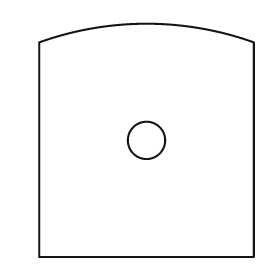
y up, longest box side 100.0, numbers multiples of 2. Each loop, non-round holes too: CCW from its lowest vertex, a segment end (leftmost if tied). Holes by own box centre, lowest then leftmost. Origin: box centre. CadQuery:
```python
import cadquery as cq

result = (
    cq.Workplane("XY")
    .moveTo(-46.0, -50.0)
    .lineTo(46.0, -50.0)
    .lineTo(46.0, 42.0)
    .threePointArc((0.0, 50.0), (-46.0, 42.0))
    .close()
    .moveTo(0.0, 0.0)
    .circle(8.0)
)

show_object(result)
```